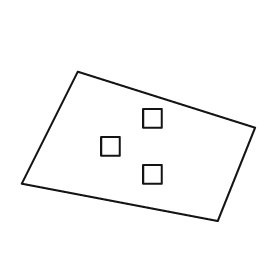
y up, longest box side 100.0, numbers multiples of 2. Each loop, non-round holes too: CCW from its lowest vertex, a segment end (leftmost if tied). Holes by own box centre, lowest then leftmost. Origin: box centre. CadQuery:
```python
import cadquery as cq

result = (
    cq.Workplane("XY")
    .moveTo(34.0, -32.0)
    .lineTo(50.0, 8.0)
    .lineTo(-26.0, 32.0)
    .lineTo(-50.0, -16.0)
    .close()
    .moveTo(2.0, -16.0)
    .lineTo(10.0, -16.0)
    .lineTo(10.0, -8.0)
    .lineTo(2.0, -8.0)
    .close()
    .moveTo(-16.0, -4.0)
    .lineTo(-8.0, -4.0)
    .lineTo(-8.0, 4.0)
    .lineTo(-16.0, 4.0)
    .close()
    .moveTo(2.0, 8.0)
    .lineTo(10.0, 8.0)
    .lineTo(10.0, 16.0)
    .lineTo(2.0, 16.0)
    .close()
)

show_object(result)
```